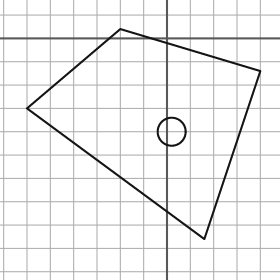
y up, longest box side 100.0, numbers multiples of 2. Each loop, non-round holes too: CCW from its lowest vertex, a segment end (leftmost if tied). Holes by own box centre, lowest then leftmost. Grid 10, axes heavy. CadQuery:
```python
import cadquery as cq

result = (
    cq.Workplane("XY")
    .moveTo(16.0, -86.0)
    .lineTo(40.0, -14.0)
    .lineTo(-20.0, 4.0)
    .lineTo(-60.0, -30.0)
    .close()
    .moveTo(2.0, -40.0)
    .circle(6.0)
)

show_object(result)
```